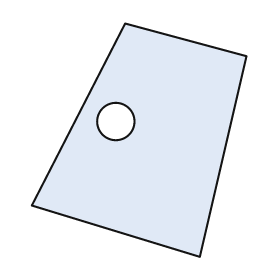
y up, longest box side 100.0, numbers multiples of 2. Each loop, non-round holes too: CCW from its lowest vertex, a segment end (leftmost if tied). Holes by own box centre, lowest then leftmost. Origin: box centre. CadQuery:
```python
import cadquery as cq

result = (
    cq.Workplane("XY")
    .moveTo(26.0, -50.0)
    .lineTo(46.0, 36.0)
    .lineTo(-6.0, 50.0)
    .lineTo(-46.0, -28.0)
    .close()
    .moveTo(-10.0, 8.0)
    .circle(8.0)
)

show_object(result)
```